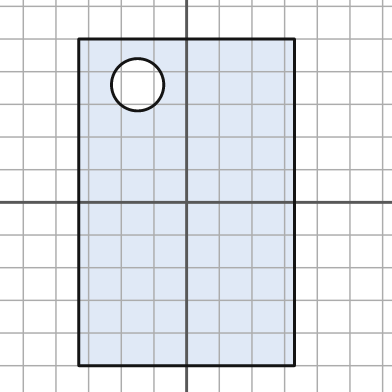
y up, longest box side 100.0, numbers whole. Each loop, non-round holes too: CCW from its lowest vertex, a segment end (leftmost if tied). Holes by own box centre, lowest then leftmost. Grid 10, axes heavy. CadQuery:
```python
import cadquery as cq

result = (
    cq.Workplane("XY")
    .moveTo(-33.0, -50.0)
    .lineTo(33.0, -50.0)
    .lineTo(33.0, 50.0)
    .lineTo(-33.0, 50.0)
    .close()
    .moveTo(-15.0, 36.0)
    .circle(8.0)
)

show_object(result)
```